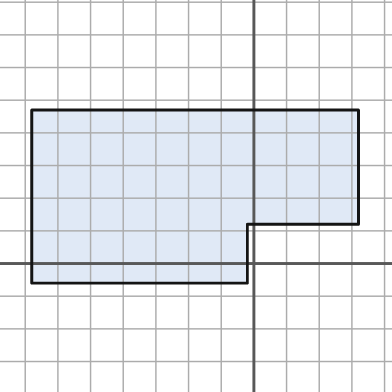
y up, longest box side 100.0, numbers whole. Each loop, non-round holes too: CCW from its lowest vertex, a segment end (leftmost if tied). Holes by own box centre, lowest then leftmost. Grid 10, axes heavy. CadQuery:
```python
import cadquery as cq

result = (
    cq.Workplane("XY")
    .moveTo(-68.0, -6.0)
    .lineTo(-2.0, -6.0)
    .lineTo(-2.0, 12.0)
    .lineTo(32.0, 12.0)
    .lineTo(32.0, 47.0)
    .lineTo(-68.0, 47.0)
    .close()
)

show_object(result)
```